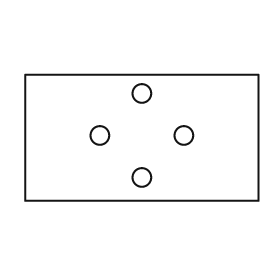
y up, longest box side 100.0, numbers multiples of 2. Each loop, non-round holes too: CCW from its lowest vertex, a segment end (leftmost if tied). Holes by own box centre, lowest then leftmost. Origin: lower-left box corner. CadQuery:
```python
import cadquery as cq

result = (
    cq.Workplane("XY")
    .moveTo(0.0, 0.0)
    .lineTo(100.0, 0.0)
    .lineTo(100.0, 54.0)
    .lineTo(0.0, 54.0)
    .close()
    .moveTo(50.0, 10.0)
    .circle(4.0)
    .moveTo(32.0, 28.0)
    .circle(4.0)
    .moveTo(68.0, 28.0)
    .circle(4.0)
    .moveTo(50.0, 46.0)
    .circle(4.0)
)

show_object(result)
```